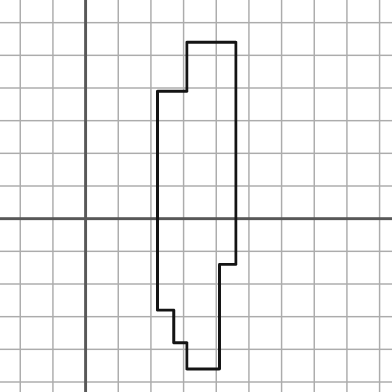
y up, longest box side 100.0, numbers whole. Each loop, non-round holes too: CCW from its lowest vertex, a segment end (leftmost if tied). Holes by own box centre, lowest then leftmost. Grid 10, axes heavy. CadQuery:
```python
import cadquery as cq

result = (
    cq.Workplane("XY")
    .moveTo(31.0, -46.0)
    .lineTo(41.0, -46.0)
    .lineTo(41.0, -14.0)
    .lineTo(46.0, -14.0)
    .lineTo(46.0, 54.0)
    .lineTo(31.0, 54.0)
    .lineTo(31.0, 39.0)
    .lineTo(22.0, 39.0)
    .lineTo(22.0, -28.0)
    .lineTo(27.0, -28.0)
    .lineTo(27.0, -38.0)
    .lineTo(31.0, -38.0)
    .close()
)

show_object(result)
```